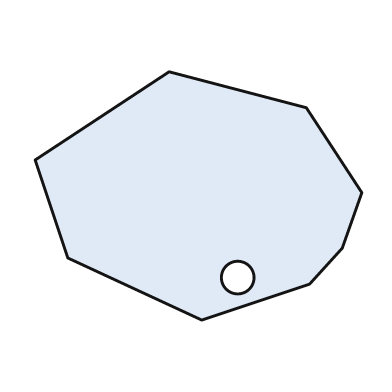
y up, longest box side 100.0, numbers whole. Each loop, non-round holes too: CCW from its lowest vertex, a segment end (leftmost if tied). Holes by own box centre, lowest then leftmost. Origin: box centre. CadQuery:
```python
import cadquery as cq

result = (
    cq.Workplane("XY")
    .moveTo(1.0, -38.0)
    .lineTo(34.0, -27.0)
    .lineTo(44.0, -16.0)
    .lineTo(50.0, 1.0)
    .lineTo(33.0, 27.0)
    .lineTo(-9.0, 38.0)
    .lineTo(-50.0, 11.0)
    .lineTo(-40.0, -19.0)
    .close()
    .moveTo(12.0, -25.0)
    .circle(5.0)
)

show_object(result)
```